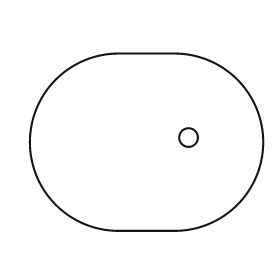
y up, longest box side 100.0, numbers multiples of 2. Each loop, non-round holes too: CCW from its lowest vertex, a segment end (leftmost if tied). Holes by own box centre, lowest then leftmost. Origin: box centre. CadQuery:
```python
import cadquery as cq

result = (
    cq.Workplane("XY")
    .moveTo(-12.0, -38.0)
    .lineTo(12.0, -38.0)
    .threePointArc((50.0, 0.0), (12.0, 38.0))
    .lineTo(-12.0, 38.0)
    .threePointArc((-50.0, 0.0), (-12.0, -38.0))
    .close()
    .moveTo(18.0, 2.0)
    .circle(4.0)
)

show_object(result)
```